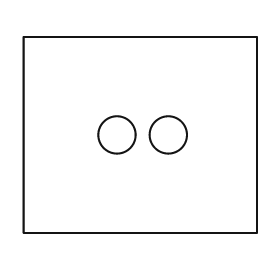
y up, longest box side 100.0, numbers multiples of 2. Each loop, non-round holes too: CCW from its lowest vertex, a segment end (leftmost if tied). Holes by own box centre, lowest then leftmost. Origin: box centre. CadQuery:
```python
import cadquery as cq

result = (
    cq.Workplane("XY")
    .moveTo(-50.0, -42.0)
    .lineTo(50.0, -42.0)
    .lineTo(50.0, 42.0)
    .lineTo(-50.0, 42.0)
    .close()
    .moveTo(-10.0, 0.0)
    .circle(8.0)
    .moveTo(12.0, 0.0)
    .circle(8.0)
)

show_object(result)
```